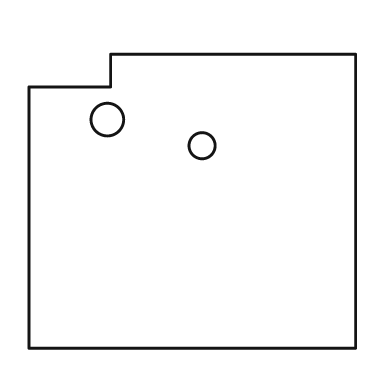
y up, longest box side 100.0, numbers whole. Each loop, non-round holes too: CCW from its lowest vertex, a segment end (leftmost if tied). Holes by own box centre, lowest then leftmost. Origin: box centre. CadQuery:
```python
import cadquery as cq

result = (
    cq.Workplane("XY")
    .moveTo(-50.0, -45.0)
    .lineTo(50.0, -45.0)
    .lineTo(50.0, 45.0)
    .lineTo(-25.0, 45.0)
    .lineTo(-25.0, 35.0)
    .lineTo(-50.0, 35.0)
    .close()
    .moveTo(3.0, 17.0)
    .circle(4.0)
    .moveTo(-26.0, 25.0)
    .circle(5.0)
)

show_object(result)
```